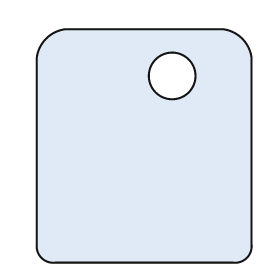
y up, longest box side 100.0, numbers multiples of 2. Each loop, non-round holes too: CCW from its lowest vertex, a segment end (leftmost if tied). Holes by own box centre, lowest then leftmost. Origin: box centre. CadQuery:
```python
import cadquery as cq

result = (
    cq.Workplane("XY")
    .moveTo(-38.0, -50.0)
    .lineTo(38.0, -50.0)
    .threePointArc((44.0, -48.0), (46.0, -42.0))
    .lineTo(46.0, 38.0)
    .threePointArc((42.0, 46.0), (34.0, 50.0))
    .lineTo(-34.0, 50.0)
    .threePointArc((-42.0, 46.0), (-46.0, 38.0))
    .lineTo(-46.0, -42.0)
    .threePointArc((-44.0, -48.0), (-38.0, -50.0))
    .close()
    .moveTo(12.0, 30.0)
    .circle(10.0)
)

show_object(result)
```